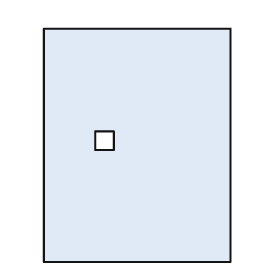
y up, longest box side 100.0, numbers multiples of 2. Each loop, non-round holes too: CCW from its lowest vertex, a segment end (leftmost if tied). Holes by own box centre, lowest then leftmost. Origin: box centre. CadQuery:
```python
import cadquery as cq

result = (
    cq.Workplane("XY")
    .moveTo(-40.0, -50.0)
    .lineTo(40.0, -50.0)
    .lineTo(40.0, 50.0)
    .lineTo(-40.0, 50.0)
    .close()
    .moveTo(-18.0, -2.0)
    .lineTo(-10.0, -2.0)
    .lineTo(-10.0, 6.0)
    .lineTo(-18.0, 6.0)
    .close()
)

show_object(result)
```